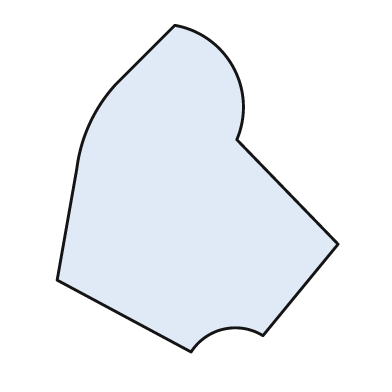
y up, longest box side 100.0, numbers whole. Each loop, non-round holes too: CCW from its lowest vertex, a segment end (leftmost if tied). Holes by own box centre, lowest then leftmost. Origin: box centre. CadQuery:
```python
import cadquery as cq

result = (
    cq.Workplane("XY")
    .moveTo(-2.0, -50.0)
    .threePointArc((8.0, -43.0), (20.0, -45.0))
    .lineTo(43.0, -17.0)
    .lineTo(12.0, 15.0)
    .threePointArc((11.0, 37.0), (-7.0, 50.0))
    .lineTo(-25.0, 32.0)
    .threePointArc((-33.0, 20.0), (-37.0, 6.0))
    .lineTo(-43.0, -28.0)
    .close()
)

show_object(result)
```